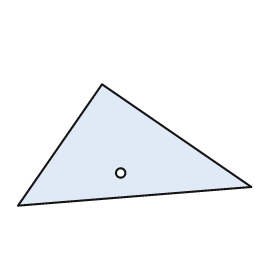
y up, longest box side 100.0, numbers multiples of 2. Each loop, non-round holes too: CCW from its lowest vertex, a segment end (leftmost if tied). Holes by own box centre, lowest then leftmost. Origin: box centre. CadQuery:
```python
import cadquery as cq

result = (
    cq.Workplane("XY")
    .moveTo(-50.0, -26.0)
    .lineTo(50.0, -18.0)
    .lineTo(-14.0, 26.0)
    .close()
    .moveTo(-6.0, -12.0)
    .circle(2.0)
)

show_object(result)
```